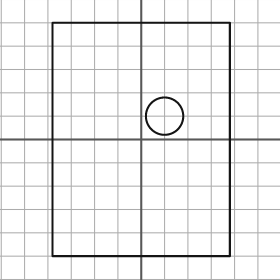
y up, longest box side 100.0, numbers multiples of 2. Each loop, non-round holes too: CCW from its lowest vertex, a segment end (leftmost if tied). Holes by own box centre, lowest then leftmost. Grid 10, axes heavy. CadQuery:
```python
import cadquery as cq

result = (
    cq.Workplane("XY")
    .moveTo(-38.0, -50.0)
    .lineTo(38.0, -50.0)
    .lineTo(38.0, 50.0)
    .lineTo(-38.0, 50.0)
    .close()
    .moveTo(10.0, 10.0)
    .circle(8.0)
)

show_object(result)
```